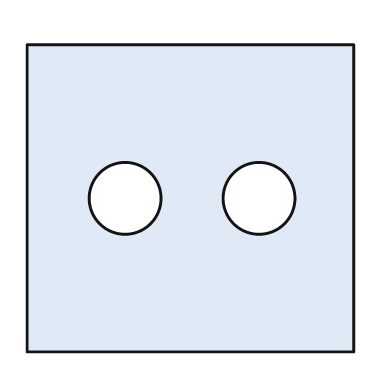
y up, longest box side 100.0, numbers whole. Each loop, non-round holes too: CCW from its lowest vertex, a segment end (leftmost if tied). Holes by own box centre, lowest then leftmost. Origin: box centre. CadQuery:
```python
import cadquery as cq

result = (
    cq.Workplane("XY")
    .moveTo(-50.0, -47.0)
    .lineTo(50.0, -47.0)
    .lineTo(50.0, 47.0)
    .lineTo(-50.0, 47.0)
    .close()
    .moveTo(-20.0, 0.0)
    .circle(11.0)
    .moveTo(21.0, 0.0)
    .circle(11.0)
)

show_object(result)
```